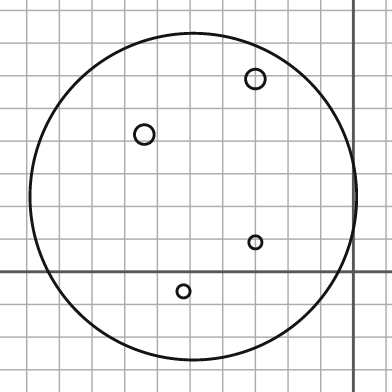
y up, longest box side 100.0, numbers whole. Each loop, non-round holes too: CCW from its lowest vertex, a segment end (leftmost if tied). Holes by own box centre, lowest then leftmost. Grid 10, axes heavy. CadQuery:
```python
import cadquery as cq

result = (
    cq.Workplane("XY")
    .moveTo(-49.0, 23.0)
    .circle(50.0)
    .moveTo(-52.0, -6.0)
    .circle(2.0)
    .moveTo(-30.0, 9.0)
    .circle(2.0)
    .moveTo(-64.0, 42.0)
    .circle(3.0)
    .moveTo(-30.0, 59.0)
    .circle(3.0)
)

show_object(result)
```